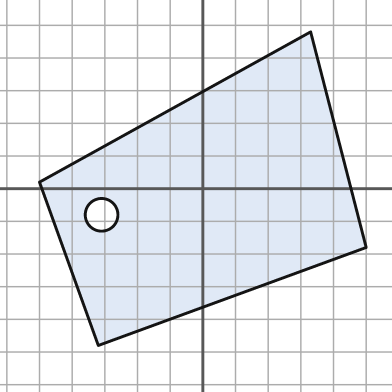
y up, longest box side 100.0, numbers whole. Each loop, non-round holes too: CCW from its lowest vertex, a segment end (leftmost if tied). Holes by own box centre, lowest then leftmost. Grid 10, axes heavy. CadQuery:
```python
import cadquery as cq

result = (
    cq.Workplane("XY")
    .moveTo(-32.0, -48.0)
    .lineTo(50.0, -18.0)
    .lineTo(33.0, 48.0)
    .lineTo(-50.0, 2.0)
    .close()
    .moveTo(-31.0, -8.0)
    .circle(5.0)
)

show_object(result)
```